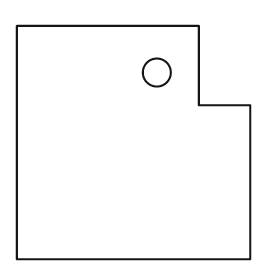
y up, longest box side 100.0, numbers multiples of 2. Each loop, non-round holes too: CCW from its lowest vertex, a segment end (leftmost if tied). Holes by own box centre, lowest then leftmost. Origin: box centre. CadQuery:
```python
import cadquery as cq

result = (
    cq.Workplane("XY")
    .moveTo(-50.0, -50.0)
    .lineTo(50.0, -50.0)
    .lineTo(50.0, 16.0)
    .lineTo(28.0, 16.0)
    .lineTo(28.0, 50.0)
    .lineTo(-50.0, 50.0)
    .close()
    .moveTo(10.0, 30.0)
    .circle(6.0)
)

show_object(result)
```